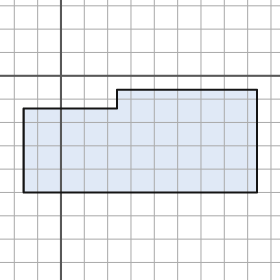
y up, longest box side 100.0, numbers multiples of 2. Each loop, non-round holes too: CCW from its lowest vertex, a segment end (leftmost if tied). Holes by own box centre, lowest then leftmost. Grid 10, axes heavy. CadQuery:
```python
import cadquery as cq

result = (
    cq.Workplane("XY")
    .moveTo(-16.0, -50.0)
    .lineTo(84.0, -50.0)
    .lineTo(84.0, -6.0)
    .lineTo(24.0, -6.0)
    .lineTo(24.0, -14.0)
    .lineTo(-16.0, -14.0)
    .close()
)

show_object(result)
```